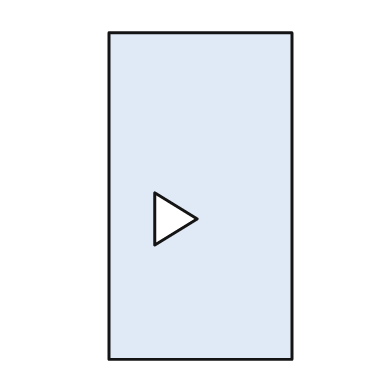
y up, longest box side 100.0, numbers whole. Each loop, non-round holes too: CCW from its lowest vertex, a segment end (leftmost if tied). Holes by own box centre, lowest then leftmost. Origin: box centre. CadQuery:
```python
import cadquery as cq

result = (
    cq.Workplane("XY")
    .moveTo(-28.0, -50.0)
    .lineTo(28.0, -50.0)
    .lineTo(28.0, 50.0)
    .lineTo(-28.0, 50.0)
    .close()
    .moveTo(-14.0, -15.0)
    .lineTo(-1.0, -7.0)
    .lineTo(-14.0, 1.0)
    .close()
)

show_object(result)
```